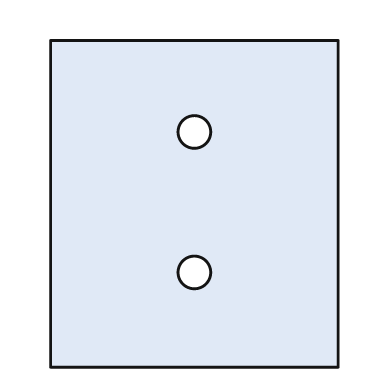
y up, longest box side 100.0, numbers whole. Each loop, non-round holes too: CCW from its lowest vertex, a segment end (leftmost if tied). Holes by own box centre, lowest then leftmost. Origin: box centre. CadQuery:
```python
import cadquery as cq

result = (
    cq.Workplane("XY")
    .moveTo(-44.0, -50.0)
    .lineTo(44.0, -50.0)
    .lineTo(44.0, 50.0)
    .lineTo(-44.0, 50.0)
    .close()
    .moveTo(0.0, -21.0)
    .circle(5.0)
    .moveTo(0.0, 22.0)
    .circle(5.0)
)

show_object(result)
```